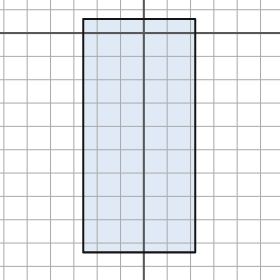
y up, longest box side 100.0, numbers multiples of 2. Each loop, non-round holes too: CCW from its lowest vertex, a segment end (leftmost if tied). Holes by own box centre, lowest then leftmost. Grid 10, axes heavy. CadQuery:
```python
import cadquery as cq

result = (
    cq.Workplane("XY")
    .moveTo(-26.0, -94.0)
    .lineTo(22.0, -94.0)
    .lineTo(22.0, 6.0)
    .lineTo(-26.0, 6.0)
    .close()
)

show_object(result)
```